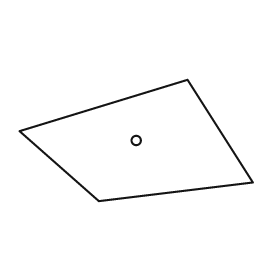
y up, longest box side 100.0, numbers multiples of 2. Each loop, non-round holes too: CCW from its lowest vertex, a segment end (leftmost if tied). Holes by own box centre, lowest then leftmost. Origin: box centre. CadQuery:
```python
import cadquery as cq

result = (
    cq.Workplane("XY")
    .moveTo(-16.0, -26.0)
    .lineTo(50.0, -18.0)
    .lineTo(22.0, 26.0)
    .lineTo(-50.0, 4.0)
    .close()
    .moveTo(0.0, 0.0)
    .circle(2.0)
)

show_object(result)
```